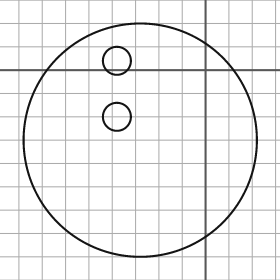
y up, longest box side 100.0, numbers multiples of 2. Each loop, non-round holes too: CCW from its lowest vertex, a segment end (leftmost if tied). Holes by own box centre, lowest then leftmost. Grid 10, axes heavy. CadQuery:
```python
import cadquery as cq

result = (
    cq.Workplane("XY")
    .moveTo(-28.0, -30.0)
    .circle(50.0)
    .moveTo(-38.0, -20.0)
    .circle(6.0)
    .moveTo(-38.0, 4.0)
    .circle(6.0)
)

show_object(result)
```